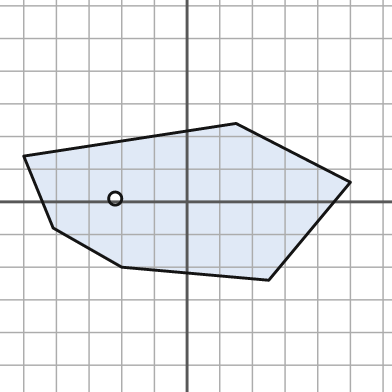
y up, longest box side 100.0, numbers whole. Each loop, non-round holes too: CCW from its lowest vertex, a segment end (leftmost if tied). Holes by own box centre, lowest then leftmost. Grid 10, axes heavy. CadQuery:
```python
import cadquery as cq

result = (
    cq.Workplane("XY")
    .moveTo(25.0, -24.0)
    .lineTo(50.0, 6.0)
    .lineTo(15.0, 24.0)
    .lineTo(-50.0, 14.0)
    .lineTo(-41.0, -8.0)
    .lineTo(-20.0, -20.0)
    .close()
    .moveTo(-22.0, 1.0)
    .circle(2.0)
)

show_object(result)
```